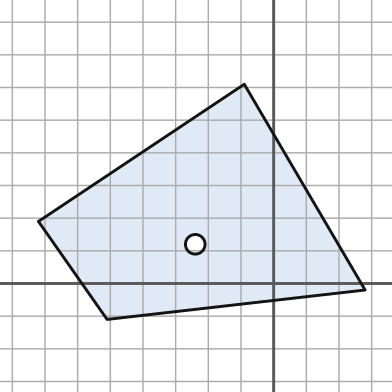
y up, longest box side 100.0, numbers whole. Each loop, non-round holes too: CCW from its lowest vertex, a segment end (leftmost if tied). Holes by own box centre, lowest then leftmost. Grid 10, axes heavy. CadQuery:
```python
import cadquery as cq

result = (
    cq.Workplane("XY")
    .moveTo(-51.0, -11.0)
    .lineTo(28.0, -2.0)
    .lineTo(-9.0, 61.0)
    .lineTo(-72.0, 19.0)
    .close()
    .moveTo(-24.0, 12.0)
    .circle(3.0)
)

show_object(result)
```